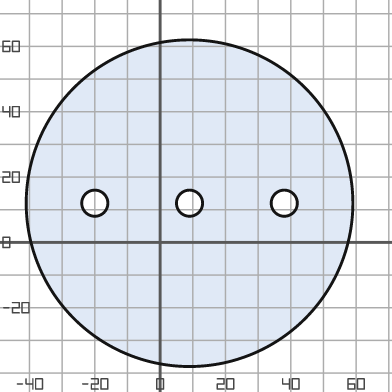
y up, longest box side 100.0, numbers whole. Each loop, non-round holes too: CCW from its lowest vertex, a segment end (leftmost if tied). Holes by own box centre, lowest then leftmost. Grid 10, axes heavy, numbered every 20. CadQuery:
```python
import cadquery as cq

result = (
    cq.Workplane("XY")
    .moveTo(9.0, 12.0)
    .circle(50.0)
    .moveTo(-20.0, 12.0)
    .circle(4.0)
    .moveTo(9.0, 12.0)
    .circle(4.0)
    .moveTo(38.0, 12.0)
    .circle(4.0)
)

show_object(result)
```